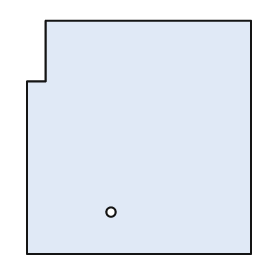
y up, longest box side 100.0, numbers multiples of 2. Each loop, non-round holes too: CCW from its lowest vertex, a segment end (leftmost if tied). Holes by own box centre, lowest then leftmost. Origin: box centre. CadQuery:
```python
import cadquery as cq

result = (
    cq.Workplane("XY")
    .moveTo(-48.0, -50.0)
    .lineTo(48.0, -50.0)
    .lineTo(48.0, 50.0)
    .lineTo(-40.0, 50.0)
    .lineTo(-40.0, 24.0)
    .lineTo(-48.0, 24.0)
    .close()
    .moveTo(-12.0, -32.0)
    .circle(2.0)
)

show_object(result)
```